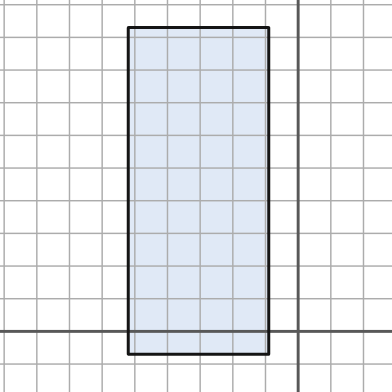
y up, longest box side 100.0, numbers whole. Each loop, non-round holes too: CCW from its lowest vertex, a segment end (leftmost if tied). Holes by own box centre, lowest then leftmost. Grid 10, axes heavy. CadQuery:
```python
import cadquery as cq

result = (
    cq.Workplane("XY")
    .moveTo(-52.0, -7.0)
    .lineTo(-9.0, -7.0)
    .lineTo(-9.0, 93.0)
    .lineTo(-52.0, 93.0)
    .close()
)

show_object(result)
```